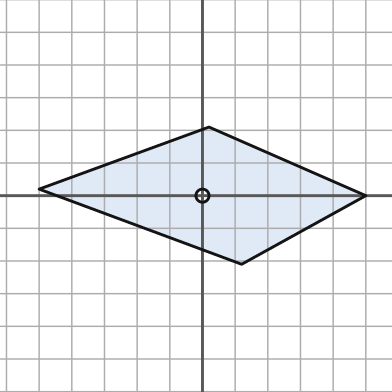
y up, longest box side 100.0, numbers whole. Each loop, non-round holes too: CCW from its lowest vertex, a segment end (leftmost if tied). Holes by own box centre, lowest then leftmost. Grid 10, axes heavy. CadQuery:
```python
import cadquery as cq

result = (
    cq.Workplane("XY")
    .moveTo(12.0, -21.0)
    .lineTo(50.0, 0.0)
    .lineTo(2.0, 21.0)
    .lineTo(-50.0, 2.0)
    .close()
    .moveTo(0.0, 0.0)
    .circle(2.0)
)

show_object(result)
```